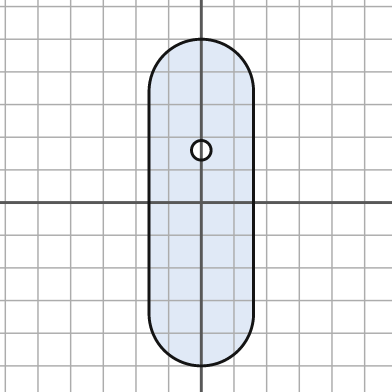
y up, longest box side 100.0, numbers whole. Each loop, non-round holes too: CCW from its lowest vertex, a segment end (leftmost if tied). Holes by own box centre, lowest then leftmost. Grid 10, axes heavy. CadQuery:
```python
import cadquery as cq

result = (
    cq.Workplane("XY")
    .moveTo(-16.0, -34.0)
    .threePointArc((0.0, -50.0), (16.0, -34.0))
    .lineTo(16.0, 34.0)
    .threePointArc((0.0, 50.0), (-16.0, 34.0))
    .close()
    .moveTo(0.0, 16.0)
    .circle(3.0)
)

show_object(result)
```